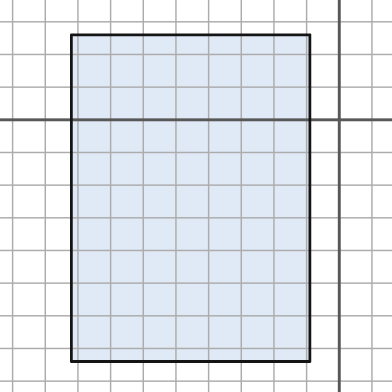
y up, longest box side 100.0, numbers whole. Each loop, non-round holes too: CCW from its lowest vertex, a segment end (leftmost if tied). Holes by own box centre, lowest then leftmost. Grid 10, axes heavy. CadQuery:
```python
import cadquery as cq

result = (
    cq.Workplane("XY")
    .moveTo(-82.0, -74.0)
    .lineTo(-9.0, -74.0)
    .lineTo(-9.0, 26.0)
    .lineTo(-82.0, 26.0)
    .close()
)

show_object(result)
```